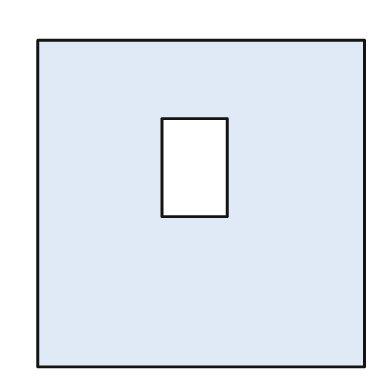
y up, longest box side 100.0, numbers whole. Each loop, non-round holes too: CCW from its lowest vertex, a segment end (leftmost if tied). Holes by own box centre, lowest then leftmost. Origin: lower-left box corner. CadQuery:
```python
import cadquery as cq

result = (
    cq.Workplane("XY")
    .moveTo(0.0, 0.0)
    .lineTo(100.0, 0.0)
    .lineTo(100.0, 100.0)
    .lineTo(0.0, 100.0)
    .close()
    .moveTo(38.0, 46.0)
    .lineTo(58.0, 46.0)
    .lineTo(58.0, 76.0)
    .lineTo(38.0, 76.0)
    .close()
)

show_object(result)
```